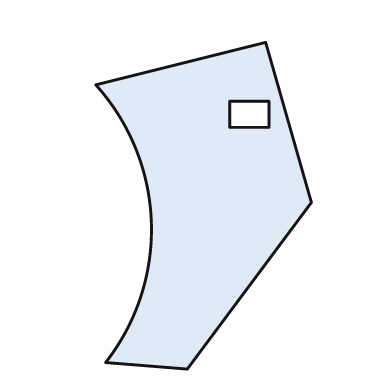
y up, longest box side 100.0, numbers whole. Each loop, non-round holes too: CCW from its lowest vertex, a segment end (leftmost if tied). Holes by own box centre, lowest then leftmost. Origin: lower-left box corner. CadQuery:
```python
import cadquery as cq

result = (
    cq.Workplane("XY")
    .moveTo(28.0, 0.0)
    .lineTo(66.0, 51.0)
    .lineTo(52.0, 100.0)
    .lineTo(0.0, 87.0)
    .threePointArc((17.0, 45.0), (3.0, 2.0))
    .close()
    .moveTo(41.0, 74.0)
    .lineTo(53.0, 74.0)
    .lineTo(53.0, 82.0)
    .lineTo(41.0, 82.0)
    .close()
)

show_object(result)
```